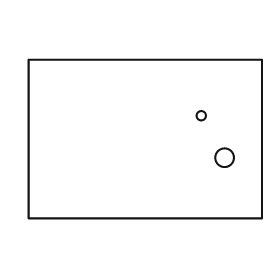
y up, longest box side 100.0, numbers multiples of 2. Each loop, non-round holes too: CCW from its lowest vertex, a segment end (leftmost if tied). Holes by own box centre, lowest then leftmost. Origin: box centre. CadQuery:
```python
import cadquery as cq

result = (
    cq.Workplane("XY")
    .moveTo(-50.0, -34.0)
    .lineTo(50.0, -34.0)
    .lineTo(50.0, 34.0)
    .lineTo(-50.0, 34.0)
    .close()
    .moveTo(34.0, -8.0)
    .circle(4.0)
    .moveTo(24.0, 10.0)
    .circle(2.0)
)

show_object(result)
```